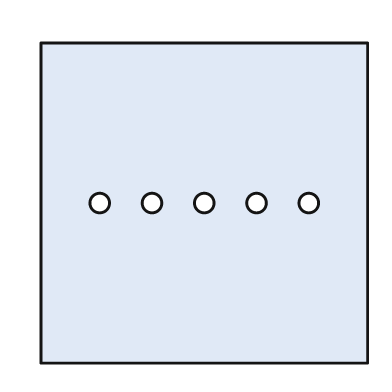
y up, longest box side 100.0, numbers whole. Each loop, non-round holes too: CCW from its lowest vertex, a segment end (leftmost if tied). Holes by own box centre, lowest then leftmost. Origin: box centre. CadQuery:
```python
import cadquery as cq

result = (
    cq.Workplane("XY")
    .moveTo(-50.0, -49.0)
    .lineTo(50.0, -49.0)
    .lineTo(50.0, 49.0)
    .lineTo(-50.0, 49.0)
    .close()
    .moveTo(-32.0, 0.0)
    .circle(3.0)
    .moveTo(-16.0, 0.0)
    .circle(3.0)
    .moveTo(0.0, 0.0)
    .circle(3.0)
    .moveTo(16.0, 0.0)
    .circle(3.0)
    .moveTo(32.0, 0.0)
    .circle(3.0)
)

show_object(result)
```